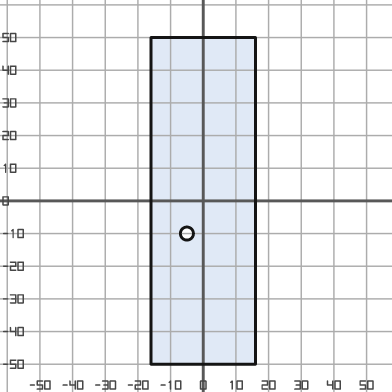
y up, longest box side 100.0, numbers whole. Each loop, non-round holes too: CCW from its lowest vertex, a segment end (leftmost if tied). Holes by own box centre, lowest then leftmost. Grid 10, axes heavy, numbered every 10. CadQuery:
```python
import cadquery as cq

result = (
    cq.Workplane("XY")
    .moveTo(-16.0, -50.0)
    .lineTo(16.0, -50.0)
    .lineTo(16.0, 50.0)
    .lineTo(-16.0, 50.0)
    .close()
    .moveTo(-5.0, -10.0)
    .circle(2.0)
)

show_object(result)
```